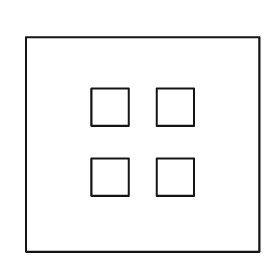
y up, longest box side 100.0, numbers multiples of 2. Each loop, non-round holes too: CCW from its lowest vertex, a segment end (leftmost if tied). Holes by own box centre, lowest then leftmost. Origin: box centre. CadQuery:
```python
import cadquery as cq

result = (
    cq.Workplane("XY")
    .moveTo(-50.0, -46.0)
    .lineTo(50.0, -46.0)
    .lineTo(50.0, 46.0)
    .lineTo(-50.0, 46.0)
    .close()
    .moveTo(-22.0, -22.0)
    .lineTo(-6.0, -22.0)
    .lineTo(-6.0, -6.0)
    .lineTo(-22.0, -6.0)
    .close()
    .moveTo(6.0, -22.0)
    .lineTo(22.0, -22.0)
    .lineTo(22.0, -6.0)
    .lineTo(6.0, -6.0)
    .close()
    .moveTo(-22.0, 8.0)
    .lineTo(-6.0, 8.0)
    .lineTo(-6.0, 24.0)
    .lineTo(-22.0, 24.0)
    .close()
    .moveTo(6.0, 8.0)
    .lineTo(22.0, 8.0)
    .lineTo(22.0, 24.0)
    .lineTo(6.0, 24.0)
    .close()
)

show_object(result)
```